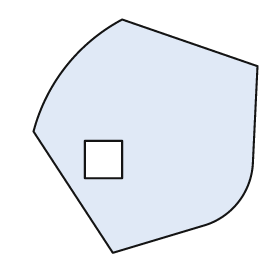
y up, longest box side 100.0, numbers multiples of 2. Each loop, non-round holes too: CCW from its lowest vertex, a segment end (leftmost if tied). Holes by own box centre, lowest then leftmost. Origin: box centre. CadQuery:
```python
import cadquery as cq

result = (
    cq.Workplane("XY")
    .moveTo(-14.0, -50.0)
    .lineTo(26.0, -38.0)
    .threePointArc((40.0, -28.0), (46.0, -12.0))
    .lineTo(48.0, 30.0)
    .lineTo(-10.0, 50.0)
    .threePointArc((-34.0, 30.0), (-48.0, 2.0))
    .close()
    .moveTo(-26.0, -18.0)
    .lineTo(-10.0, -18.0)
    .lineTo(-10.0, -2.0)
    .lineTo(-26.0, -2.0)
    .close()
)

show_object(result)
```